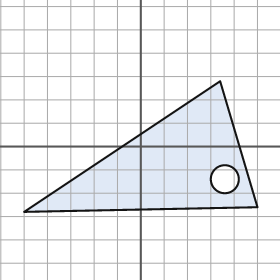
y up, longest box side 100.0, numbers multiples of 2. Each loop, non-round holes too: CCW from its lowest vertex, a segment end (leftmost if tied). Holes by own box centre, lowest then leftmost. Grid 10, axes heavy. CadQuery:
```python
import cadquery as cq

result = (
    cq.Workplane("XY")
    .moveTo(-50.0, -28.0)
    .lineTo(50.0, -26.0)
    .lineTo(34.0, 28.0)
    .close()
    .moveTo(36.0, -14.0)
    .circle(6.0)
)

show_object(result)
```